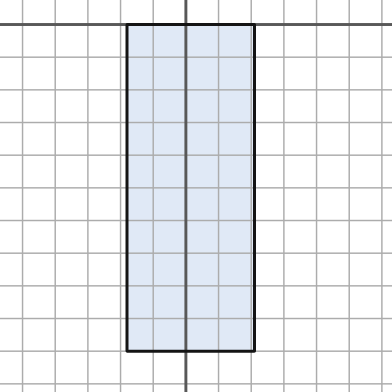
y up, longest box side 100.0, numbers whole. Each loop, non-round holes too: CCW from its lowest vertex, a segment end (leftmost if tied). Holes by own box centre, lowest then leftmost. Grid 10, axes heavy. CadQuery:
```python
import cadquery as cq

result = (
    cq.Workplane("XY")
    .moveTo(-18.0, -100.0)
    .lineTo(21.0, -100.0)
    .lineTo(21.0, 0.0)
    .lineTo(-18.0, 0.0)
    .close()
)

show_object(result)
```